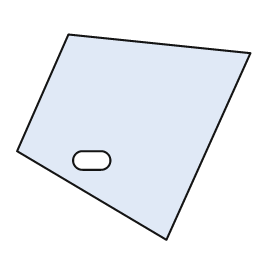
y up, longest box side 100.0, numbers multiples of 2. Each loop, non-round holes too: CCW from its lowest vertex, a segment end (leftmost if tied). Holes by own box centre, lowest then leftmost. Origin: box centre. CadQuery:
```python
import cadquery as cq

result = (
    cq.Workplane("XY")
    .moveTo(14.0, -44.0)
    .lineTo(50.0, 36.0)
    .lineTo(-28.0, 44.0)
    .lineTo(-50.0, -6.0)
    .close()
    .moveTo(-22.0, -14.0)
    .lineTo(-14.0, -14.0)
    .threePointArc((-10.0, -10.0), (-14.0, -6.0))
    .lineTo(-22.0, -6.0)
    .threePointArc((-26.0, -10.0), (-22.0, -14.0))
    .close()
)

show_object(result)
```